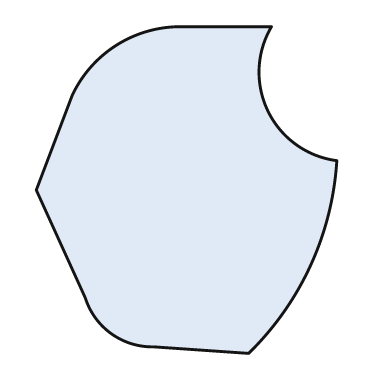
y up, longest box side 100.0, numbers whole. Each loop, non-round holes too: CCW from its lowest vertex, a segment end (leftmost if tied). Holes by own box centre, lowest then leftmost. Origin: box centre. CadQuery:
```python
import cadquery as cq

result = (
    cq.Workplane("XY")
    .moveTo(19.0, -50.0)
    .threePointArc((38.0, -23.0), (46.0, 9.0))
    .threePointArc((25.0, 24.0), (26.0, 50.0))
    .lineTo(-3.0, 50.0)
    .threePointArc((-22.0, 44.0), (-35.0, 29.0))
    .lineTo(-46.0, 0.0)
    .lineTo(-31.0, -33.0)
    .threePointArc((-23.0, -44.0), (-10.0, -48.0))
    .close()
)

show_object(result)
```